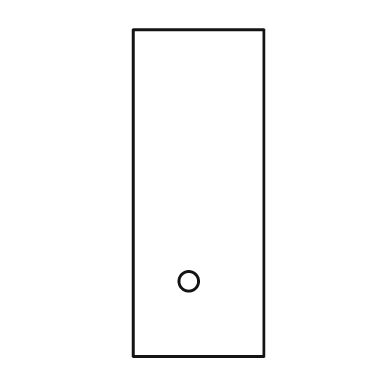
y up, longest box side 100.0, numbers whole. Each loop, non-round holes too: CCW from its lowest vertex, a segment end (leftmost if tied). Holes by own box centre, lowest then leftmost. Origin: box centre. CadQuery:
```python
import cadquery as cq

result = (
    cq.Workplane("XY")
    .moveTo(-20.0, -50.0)
    .lineTo(20.0, -50.0)
    .lineTo(20.0, 50.0)
    .lineTo(-20.0, 50.0)
    .close()
    .moveTo(-3.0, -27.0)
    .circle(3.0)
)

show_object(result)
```